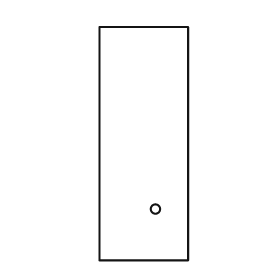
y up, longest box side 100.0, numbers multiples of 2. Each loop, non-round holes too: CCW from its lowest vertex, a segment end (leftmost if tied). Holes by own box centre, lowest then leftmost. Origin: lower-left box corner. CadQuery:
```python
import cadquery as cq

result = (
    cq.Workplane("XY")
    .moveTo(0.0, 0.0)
    .lineTo(38.0, 0.0)
    .lineTo(38.0, 100.0)
    .lineTo(0.0, 100.0)
    .close()
    .moveTo(24.0, 22.0)
    .circle(2.0)
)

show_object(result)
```